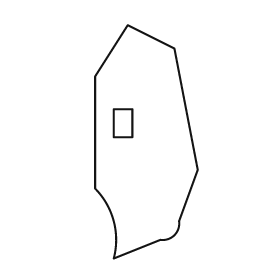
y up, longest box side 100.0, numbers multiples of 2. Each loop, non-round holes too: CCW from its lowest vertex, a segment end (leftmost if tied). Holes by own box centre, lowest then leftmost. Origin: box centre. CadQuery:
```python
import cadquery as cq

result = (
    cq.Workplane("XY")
    .moveTo(-14.0, -50.0)
    .lineTo(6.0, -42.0)
    .threePointArc((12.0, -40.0), (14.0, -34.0))
    .lineTo(22.0, -12.0)
    .lineTo(12.0, 40.0)
    .lineTo(-8.0, 50.0)
    .lineTo(-22.0, 28.0)
    .lineTo(-22.0, -20.0)
    .threePointArc((-14.0, -34.0), (-14.0, -50.0))
    .close()
    .moveTo(-14.0, 2.0)
    .lineTo(-6.0, 2.0)
    .lineTo(-6.0, 14.0)
    .lineTo(-14.0, 14.0)
    .close()
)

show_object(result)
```